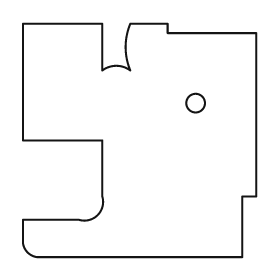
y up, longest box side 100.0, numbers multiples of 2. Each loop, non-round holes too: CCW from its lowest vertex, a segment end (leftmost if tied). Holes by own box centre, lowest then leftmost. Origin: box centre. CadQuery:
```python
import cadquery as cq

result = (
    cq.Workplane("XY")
    .moveTo(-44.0, -50.0)
    .lineTo(44.0, -50.0)
    .lineTo(44.0, -24.0)
    .lineTo(50.0, -24.0)
    .lineTo(50.0, 46.0)
    .lineTo(12.0, 46.0)
    .lineTo(12.0, 50.0)
    .lineTo(-4.0, 50.0)
    .threePointArc((-6.0, 40.0), (-4.0, 30.0))
    .threePointArc((-10.0, 32.0), (-16.0, 30.0))
    .lineTo(-16.0, 50.0)
    .lineTo(-50.0, 50.0)
    .lineTo(-50.0, 0.0)
    .lineTo(-16.0, 0.0)
    .lineTo(-16.0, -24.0)
    .threePointArc((-18.0, -32.0), (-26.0, -34.0))
    .lineTo(-50.0, -34.0)
    .lineTo(-50.0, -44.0)
    .threePointArc((-48.0, -48.0), (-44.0, -50.0))
    .close()
    .moveTo(24.0, 16.0)
    .circle(4.0)
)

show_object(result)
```